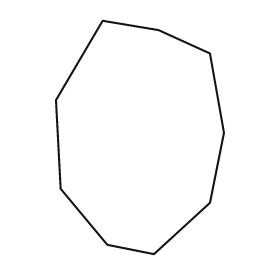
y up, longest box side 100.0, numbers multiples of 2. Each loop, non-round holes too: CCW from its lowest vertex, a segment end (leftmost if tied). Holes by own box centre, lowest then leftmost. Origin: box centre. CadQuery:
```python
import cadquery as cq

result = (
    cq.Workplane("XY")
    .moveTo(6.0, -50.0)
    .lineTo(30.0, -28.0)
    .lineTo(36.0, 2.0)
    .lineTo(30.0, 36.0)
    .lineTo(8.0, 46.0)
    .lineTo(-16.0, 50.0)
    .lineTo(-36.0, 16.0)
    .lineTo(-34.0, -22.0)
    .lineTo(-14.0, -46.0)
    .close()
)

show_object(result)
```